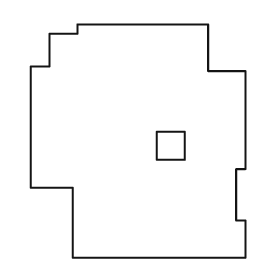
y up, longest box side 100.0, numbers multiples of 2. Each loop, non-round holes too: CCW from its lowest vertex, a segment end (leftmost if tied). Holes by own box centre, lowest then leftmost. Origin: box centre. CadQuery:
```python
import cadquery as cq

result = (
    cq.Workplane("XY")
    .moveTo(-28.0, -50.0)
    .lineTo(46.0, -50.0)
    .lineTo(46.0, -34.0)
    .lineTo(42.0, -34.0)
    .lineTo(42.0, -12.0)
    .lineTo(46.0, -12.0)
    .lineTo(46.0, 30.0)
    .lineTo(30.0, 30.0)
    .lineTo(30.0, 50.0)
    .lineTo(-26.0, 50.0)
    .lineTo(-26.0, 46.0)
    .lineTo(-38.0, 46.0)
    .lineTo(-38.0, 32.0)
    .lineTo(-46.0, 32.0)
    .lineTo(-46.0, -20.0)
    .lineTo(-28.0, -20.0)
    .close()
    .moveTo(8.0, -8.0)
    .lineTo(20.0, -8.0)
    .lineTo(20.0, 4.0)
    .lineTo(8.0, 4.0)
    .close()
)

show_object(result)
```